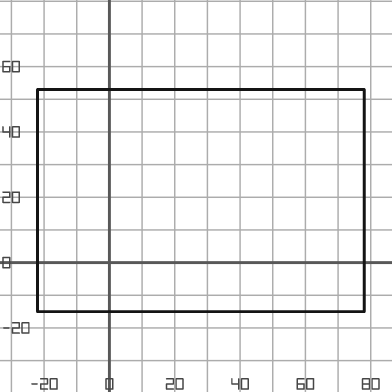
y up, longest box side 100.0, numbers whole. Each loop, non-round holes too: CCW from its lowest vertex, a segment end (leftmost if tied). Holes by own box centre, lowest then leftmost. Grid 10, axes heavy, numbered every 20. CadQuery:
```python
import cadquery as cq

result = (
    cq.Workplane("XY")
    .moveTo(-22.0, -15.0)
    .lineTo(78.0, -15.0)
    .lineTo(78.0, 53.0)
    .lineTo(-22.0, 53.0)
    .close()
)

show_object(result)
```